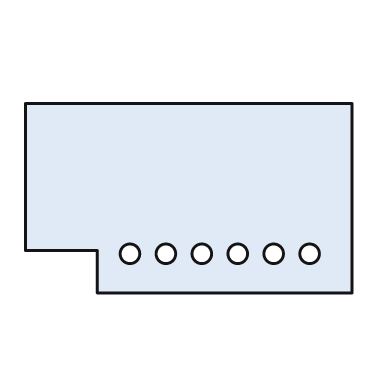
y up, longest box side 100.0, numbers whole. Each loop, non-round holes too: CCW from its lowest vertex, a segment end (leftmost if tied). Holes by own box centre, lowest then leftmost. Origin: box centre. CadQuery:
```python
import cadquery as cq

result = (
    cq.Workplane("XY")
    .moveTo(-28.0, -29.0)
    .lineTo(50.0, -29.0)
    .lineTo(50.0, 29.0)
    .lineTo(-50.0, 29.0)
    .lineTo(-50.0, -16.0)
    .lineTo(-28.0, -16.0)
    .close()
    .moveTo(-18.0, -17.0)
    .circle(3.0)
    .moveTo(-7.0, -17.0)
    .circle(3.0)
    .moveTo(4.0, -17.0)
    .circle(3.0)
    .moveTo(15.0, -17.0)
    .circle(3.0)
    .moveTo(26.0, -17.0)
    .circle(3.0)
    .moveTo(37.0, -17.0)
    .circle(3.0)
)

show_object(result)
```